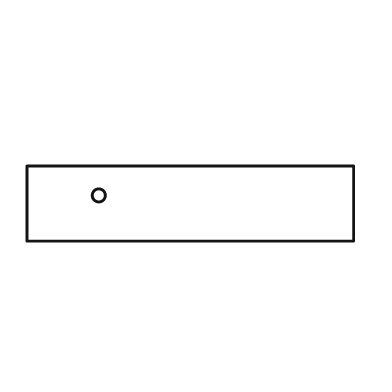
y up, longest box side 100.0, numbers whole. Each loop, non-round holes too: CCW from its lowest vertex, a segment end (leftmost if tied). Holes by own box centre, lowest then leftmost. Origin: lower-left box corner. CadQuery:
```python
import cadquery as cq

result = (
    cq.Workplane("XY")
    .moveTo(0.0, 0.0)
    .lineTo(100.0, 0.0)
    .lineTo(100.0, 23.0)
    .lineTo(0.0, 23.0)
    .close()
    .moveTo(22.0, 14.0)
    .circle(2.0)
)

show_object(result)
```